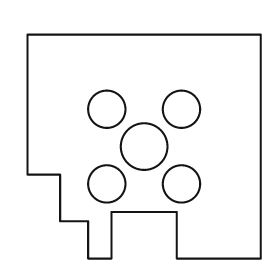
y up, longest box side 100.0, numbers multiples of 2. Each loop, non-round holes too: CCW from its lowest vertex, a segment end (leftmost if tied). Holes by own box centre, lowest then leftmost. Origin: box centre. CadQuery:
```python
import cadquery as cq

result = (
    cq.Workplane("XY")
    .moveTo(-24.0, -48.0)
    .lineTo(-14.0, -48.0)
    .lineTo(-14.0, -28.0)
    .lineTo(14.0, -28.0)
    .lineTo(14.0, -48.0)
    .lineTo(50.0, -48.0)
    .lineTo(50.0, 48.0)
    .lineTo(-50.0, 48.0)
    .lineTo(-50.0, -12.0)
    .lineTo(-36.0, -12.0)
    .lineTo(-36.0, -32.0)
    .lineTo(-24.0, -32.0)
    .close()
    .moveTo(-16.0, -16.0)
    .circle(8.0)
    .moveTo(16.0, -16.0)
    .circle(8.0)
    .moveTo(0.0, 0.0)
    .circle(10.0)
    .moveTo(-16.0, 16.0)
    .circle(8.0)
    .moveTo(16.0, 16.0)
    .circle(8.0)
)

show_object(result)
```